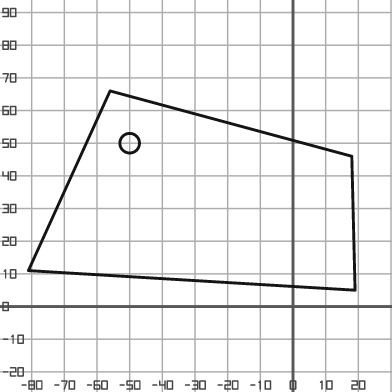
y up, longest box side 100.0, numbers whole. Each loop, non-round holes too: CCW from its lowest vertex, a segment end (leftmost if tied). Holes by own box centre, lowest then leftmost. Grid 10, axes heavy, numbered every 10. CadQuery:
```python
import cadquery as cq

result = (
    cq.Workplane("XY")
    .moveTo(19.0, 5.0)
    .lineTo(18.0, 46.0)
    .lineTo(-56.0, 66.0)
    .lineTo(-81.0, 11.0)
    .close()
    .moveTo(-50.0, 50.0)
    .circle(3.0)
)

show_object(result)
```